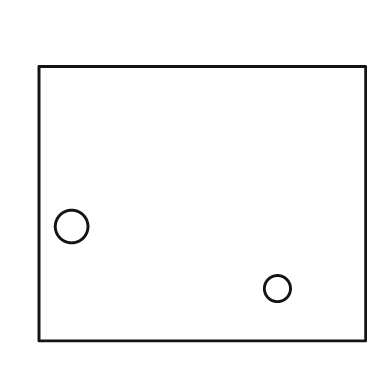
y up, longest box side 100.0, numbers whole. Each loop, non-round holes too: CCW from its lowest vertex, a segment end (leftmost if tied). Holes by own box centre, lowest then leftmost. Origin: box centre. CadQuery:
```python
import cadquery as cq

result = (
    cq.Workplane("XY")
    .moveTo(-50.0, -42.0)
    .lineTo(50.0, -42.0)
    .lineTo(50.0, 42.0)
    .lineTo(-50.0, 42.0)
    .close()
    .moveTo(23.0, -26.0)
    .circle(4.0)
    .moveTo(-40.0, -7.0)
    .circle(5.0)
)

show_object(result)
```